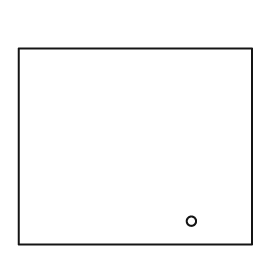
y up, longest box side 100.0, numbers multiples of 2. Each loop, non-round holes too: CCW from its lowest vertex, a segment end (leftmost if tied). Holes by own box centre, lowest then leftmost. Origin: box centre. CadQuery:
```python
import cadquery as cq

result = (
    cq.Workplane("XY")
    .moveTo(-50.0, -42.0)
    .lineTo(50.0, -42.0)
    .lineTo(50.0, 42.0)
    .lineTo(-50.0, 42.0)
    .close()
    .moveTo(24.0, -32.0)
    .circle(2.0)
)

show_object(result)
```